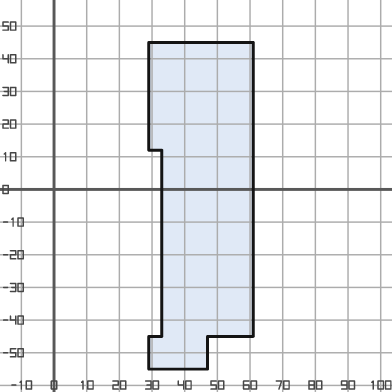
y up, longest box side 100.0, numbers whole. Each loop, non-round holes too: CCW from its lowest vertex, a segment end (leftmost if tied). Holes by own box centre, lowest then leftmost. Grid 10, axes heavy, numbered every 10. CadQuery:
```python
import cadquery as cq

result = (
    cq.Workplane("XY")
    .moveTo(29.0, -55.0)
    .lineTo(47.0, -55.0)
    .lineTo(47.0, -45.0)
    .lineTo(61.0, -45.0)
    .lineTo(61.0, 45.0)
    .lineTo(29.0, 45.0)
    .lineTo(29.0, 12.0)
    .lineTo(33.0, 12.0)
    .lineTo(33.0, -45.0)
    .lineTo(29.0, -45.0)
    .close()
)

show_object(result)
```